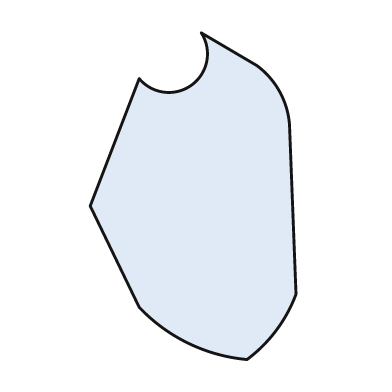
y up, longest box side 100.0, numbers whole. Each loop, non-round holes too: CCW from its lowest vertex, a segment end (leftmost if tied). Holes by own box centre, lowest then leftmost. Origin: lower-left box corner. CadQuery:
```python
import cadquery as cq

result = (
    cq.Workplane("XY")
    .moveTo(48.0, 0.0)
    .threePointArc((57.0, 9.0), (63.0, 20.0))
    .lineTo(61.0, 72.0)
    .threePointArc((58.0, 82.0), (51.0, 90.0))
    .lineTo(34.0, 100.0)
    .threePointArc((31.0, 84.0), (15.0, 86.0))
    .lineTo(0.0, 47.0)
    .lineTo(15.0, 16.0)
    .threePointArc((30.0, 5.0), (48.0, 0.0))
    .close()
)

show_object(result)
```